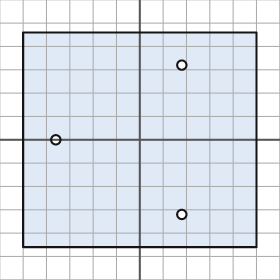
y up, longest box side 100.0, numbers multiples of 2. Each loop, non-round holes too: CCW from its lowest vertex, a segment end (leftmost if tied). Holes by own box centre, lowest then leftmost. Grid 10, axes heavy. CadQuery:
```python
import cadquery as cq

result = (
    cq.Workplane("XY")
    .moveTo(-50.0, -46.0)
    .lineTo(50.0, -46.0)
    .lineTo(50.0, 46.0)
    .lineTo(-50.0, 46.0)
    .close()
    .moveTo(18.0, -32.0)
    .circle(2.0)
    .moveTo(-36.0, 0.0)
    .circle(2.0)
    .moveTo(18.0, 32.0)
    .circle(2.0)
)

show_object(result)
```